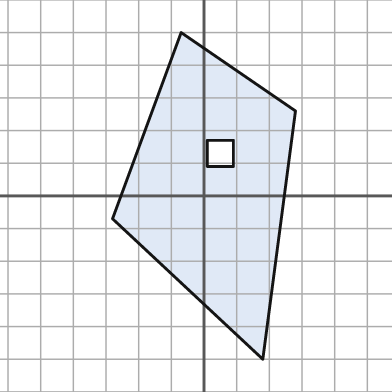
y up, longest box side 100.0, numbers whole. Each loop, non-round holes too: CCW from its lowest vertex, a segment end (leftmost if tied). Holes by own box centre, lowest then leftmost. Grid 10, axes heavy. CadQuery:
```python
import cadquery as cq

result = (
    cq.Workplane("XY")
    .moveTo(18.0, -50.0)
    .lineTo(28.0, 26.0)
    .lineTo(-7.0, 50.0)
    .lineTo(-28.0, -7.0)
    .close()
    .moveTo(1.0, 9.0)
    .lineTo(9.0, 9.0)
    .lineTo(9.0, 17.0)
    .lineTo(1.0, 17.0)
    .close()
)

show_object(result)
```